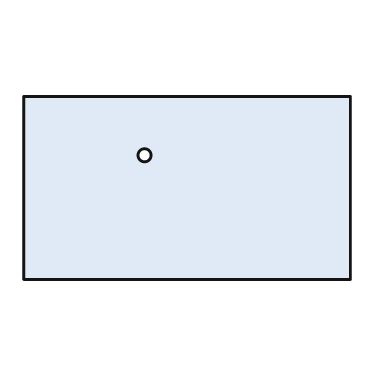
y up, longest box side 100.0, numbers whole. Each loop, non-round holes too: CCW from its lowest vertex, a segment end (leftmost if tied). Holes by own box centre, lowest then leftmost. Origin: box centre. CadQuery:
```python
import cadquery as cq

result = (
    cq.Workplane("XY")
    .moveTo(-50.0, -28.0)
    .lineTo(50.0, -28.0)
    .lineTo(50.0, 28.0)
    .lineTo(-50.0, 28.0)
    .close()
    .moveTo(-13.0, 10.0)
    .circle(2.0)
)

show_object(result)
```